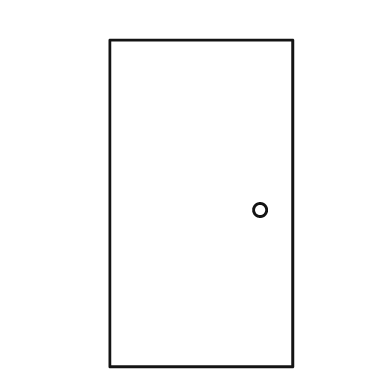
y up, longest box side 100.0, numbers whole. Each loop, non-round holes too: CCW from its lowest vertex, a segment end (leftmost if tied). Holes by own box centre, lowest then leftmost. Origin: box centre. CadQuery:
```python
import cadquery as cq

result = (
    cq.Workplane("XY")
    .moveTo(-28.0, -50.0)
    .lineTo(28.0, -50.0)
    .lineTo(28.0, 50.0)
    .lineTo(-28.0, 50.0)
    .close()
    .moveTo(18.0, -2.0)
    .circle(2.0)
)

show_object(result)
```